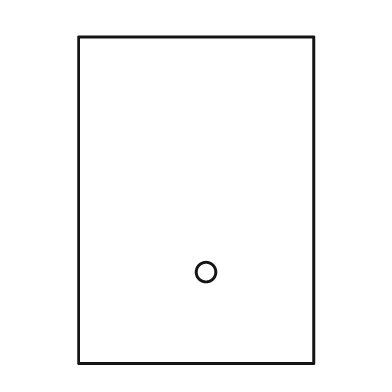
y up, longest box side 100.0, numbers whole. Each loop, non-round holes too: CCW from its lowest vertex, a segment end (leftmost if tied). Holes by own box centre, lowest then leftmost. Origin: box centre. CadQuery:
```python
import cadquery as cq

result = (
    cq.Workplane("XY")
    .moveTo(-36.0, -50.0)
    .lineTo(36.0, -50.0)
    .lineTo(36.0, 50.0)
    .lineTo(-36.0, 50.0)
    .close()
    .moveTo(3.0, -22.0)
    .circle(3.0)
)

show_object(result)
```